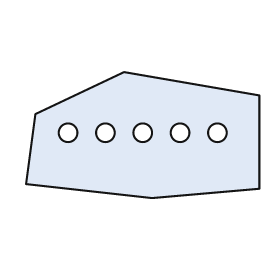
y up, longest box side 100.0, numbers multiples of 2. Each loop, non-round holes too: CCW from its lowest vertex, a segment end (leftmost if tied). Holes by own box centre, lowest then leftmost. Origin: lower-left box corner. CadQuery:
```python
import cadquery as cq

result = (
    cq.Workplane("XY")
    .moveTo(54.0, 0.0)
    .lineTo(100.0, 4.0)
    .lineTo(100.0, 44.0)
    .lineTo(42.0, 54.0)
    .lineTo(4.0, 36.0)
    .lineTo(0.0, 6.0)
    .close()
    .moveTo(18.0, 28.0)
    .circle(4.0)
    .moveTo(34.0, 28.0)
    .circle(4.0)
    .moveTo(50.0, 28.0)
    .circle(4.0)
    .moveTo(66.0, 28.0)
    .circle(4.0)
    .moveTo(82.0, 28.0)
    .circle(4.0)
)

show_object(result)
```